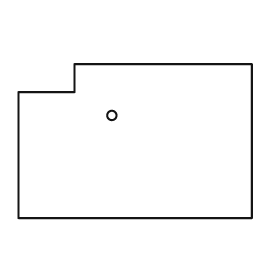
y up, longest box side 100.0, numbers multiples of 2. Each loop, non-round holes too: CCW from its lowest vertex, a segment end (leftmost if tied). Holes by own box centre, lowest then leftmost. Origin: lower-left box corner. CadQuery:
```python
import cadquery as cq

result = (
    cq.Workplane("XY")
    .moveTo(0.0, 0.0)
    .lineTo(100.0, 0.0)
    .lineTo(100.0, 66.0)
    .lineTo(24.0, 66.0)
    .lineTo(24.0, 54.0)
    .lineTo(0.0, 54.0)
    .close()
    .moveTo(40.0, 44.0)
    .circle(2.0)
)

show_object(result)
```